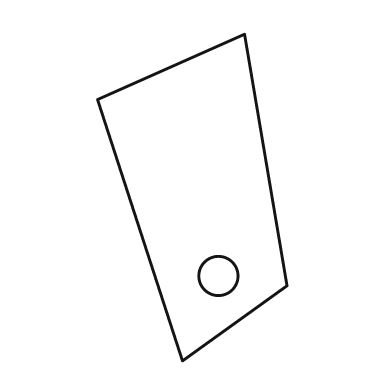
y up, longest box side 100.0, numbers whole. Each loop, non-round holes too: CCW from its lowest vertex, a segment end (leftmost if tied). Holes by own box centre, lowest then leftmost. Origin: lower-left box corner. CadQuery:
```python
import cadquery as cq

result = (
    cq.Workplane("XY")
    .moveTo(26.0, 0.0)
    .lineTo(58.0, 23.0)
    .lineTo(45.0, 100.0)
    .lineTo(0.0, 80.0)
    .close()
    .moveTo(37.0, 26.0)
    .circle(6.0)
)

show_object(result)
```